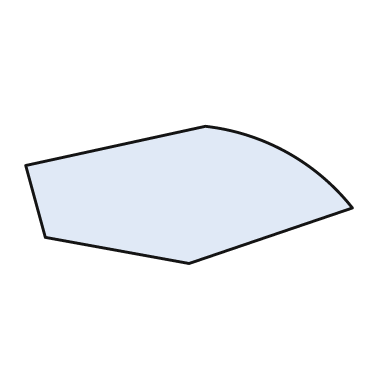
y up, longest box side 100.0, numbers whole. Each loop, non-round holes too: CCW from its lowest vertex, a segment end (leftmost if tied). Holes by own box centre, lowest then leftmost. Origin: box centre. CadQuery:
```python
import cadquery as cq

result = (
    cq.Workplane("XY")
    .moveTo(0.0, -21.0)
    .lineTo(50.0, -4.0)
    .threePointArc((30.0, 13.0), (5.0, 21.0))
    .lineTo(-50.0, 9.0)
    .lineTo(-44.0, -13.0)
    .close()
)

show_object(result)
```